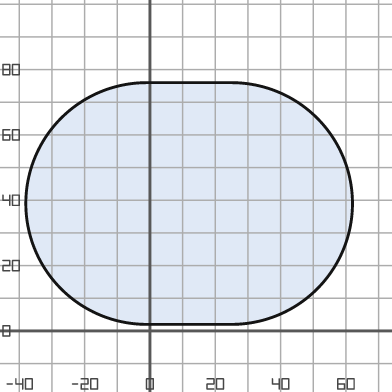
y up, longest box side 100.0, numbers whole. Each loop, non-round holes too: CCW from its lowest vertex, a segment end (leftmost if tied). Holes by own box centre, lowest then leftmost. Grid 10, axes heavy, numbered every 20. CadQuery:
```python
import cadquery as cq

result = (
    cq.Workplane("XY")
    .moveTo(-1.0, 2.0)
    .lineTo(25.0, 2.0)
    .threePointArc((62.0, 39.0), (25.0, 76.0))
    .lineTo(-1.0, 76.0)
    .threePointArc((-38.0, 39.0), (-1.0, 2.0))
    .close()
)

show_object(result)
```